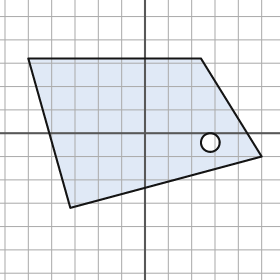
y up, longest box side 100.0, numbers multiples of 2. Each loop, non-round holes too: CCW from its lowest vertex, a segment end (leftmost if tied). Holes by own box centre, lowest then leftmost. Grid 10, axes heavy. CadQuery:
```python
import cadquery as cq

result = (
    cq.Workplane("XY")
    .moveTo(-32.0, -32.0)
    .lineTo(50.0, -10.0)
    .lineTo(24.0, 32.0)
    .lineTo(-50.0, 32.0)
    .close()
    .moveTo(28.0, -4.0)
    .circle(4.0)
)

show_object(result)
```